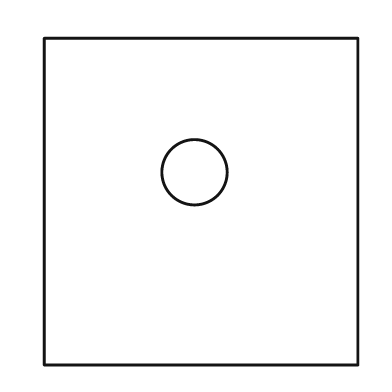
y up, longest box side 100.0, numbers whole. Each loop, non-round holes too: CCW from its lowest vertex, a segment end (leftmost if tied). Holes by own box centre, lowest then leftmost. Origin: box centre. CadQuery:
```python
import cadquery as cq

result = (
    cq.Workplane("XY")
    .moveTo(-48.0, -50.0)
    .lineTo(48.0, -50.0)
    .lineTo(48.0, 50.0)
    .lineTo(-48.0, 50.0)
    .close()
    .moveTo(-2.0, 9.0)
    .circle(10.0)
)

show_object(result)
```